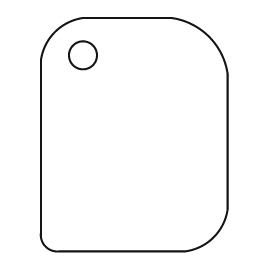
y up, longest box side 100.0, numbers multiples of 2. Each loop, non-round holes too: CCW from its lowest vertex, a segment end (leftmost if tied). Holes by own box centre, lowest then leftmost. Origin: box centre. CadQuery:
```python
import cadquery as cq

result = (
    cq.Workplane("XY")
    .moveTo(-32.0, -50.0)
    .lineTo(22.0, -50.0)
    .threePointArc((34.0, -44.0), (40.0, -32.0))
    .lineTo(40.0, 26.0)
    .threePointArc((32.0, 42.0), (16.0, 50.0))
    .lineTo(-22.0, 50.0)
    .threePointArc((-34.0, 44.0), (-40.0, 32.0))
    .lineTo(-40.0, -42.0)
    .threePointArc((-38.0, -48.0), (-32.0, -50.0))
    .close()
    .moveTo(-22.0, 34.0)
    .circle(6.0)
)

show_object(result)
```